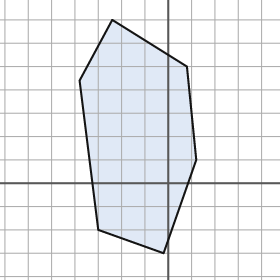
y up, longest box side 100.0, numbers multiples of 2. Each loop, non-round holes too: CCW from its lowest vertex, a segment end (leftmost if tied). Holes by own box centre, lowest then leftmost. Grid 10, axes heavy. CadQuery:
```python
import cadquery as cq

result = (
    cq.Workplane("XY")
    .moveTo(-2.0, -30.0)
    .lineTo(12.0, 10.0)
    .lineTo(8.0, 50.0)
    .lineTo(-24.0, 70.0)
    .lineTo(-38.0, 44.0)
    .lineTo(-30.0, -20.0)
    .close()
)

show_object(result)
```